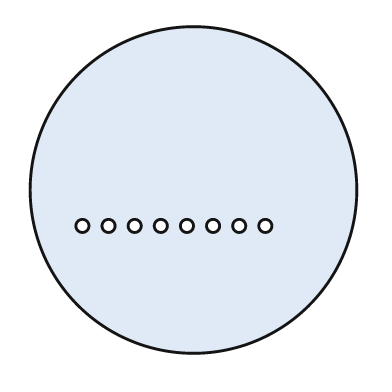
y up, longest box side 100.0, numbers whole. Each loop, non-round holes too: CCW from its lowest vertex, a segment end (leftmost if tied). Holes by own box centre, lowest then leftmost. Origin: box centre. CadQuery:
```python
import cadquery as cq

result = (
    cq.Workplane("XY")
    .moveTo(0.0, 0.0)
    .circle(50.0)
    .moveTo(-34.0, -11.0)
    .circle(2.0)
    .moveTo(-26.0, -11.0)
    .circle(2.0)
    .moveTo(-18.0, -11.0)
    .circle(2.0)
    .moveTo(-10.0, -11.0)
    .circle(2.0)
    .moveTo(-2.0, -11.0)
    .circle(2.0)
    .moveTo(6.0, -11.0)
    .circle(2.0)
    .moveTo(14.0, -11.0)
    .circle(2.0)
    .moveTo(22.0, -11.0)
    .circle(2.0)
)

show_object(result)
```